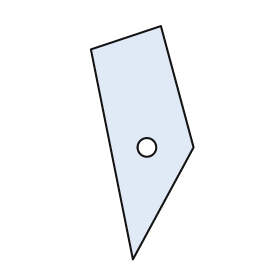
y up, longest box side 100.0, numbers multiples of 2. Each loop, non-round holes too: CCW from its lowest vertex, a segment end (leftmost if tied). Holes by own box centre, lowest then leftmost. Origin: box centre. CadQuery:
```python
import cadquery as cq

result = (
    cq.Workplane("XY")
    .moveTo(-4.0, -50.0)
    .lineTo(22.0, -2.0)
    .lineTo(8.0, 50.0)
    .lineTo(-22.0, 40.0)
    .close()
    .moveTo(2.0, -2.0)
    .circle(4.0)
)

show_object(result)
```